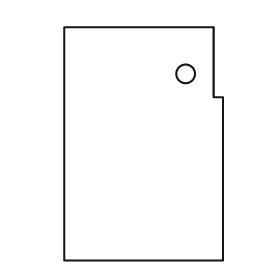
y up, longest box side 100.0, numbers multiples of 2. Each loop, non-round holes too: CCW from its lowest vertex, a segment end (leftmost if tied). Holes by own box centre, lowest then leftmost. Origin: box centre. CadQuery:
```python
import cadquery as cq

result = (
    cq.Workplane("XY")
    .moveTo(-34.0, -50.0)
    .lineTo(34.0, -50.0)
    .lineTo(34.0, 20.0)
    .lineTo(30.0, 20.0)
    .lineTo(30.0, 50.0)
    .lineTo(-34.0, 50.0)
    .close()
    .moveTo(18.0, 30.0)
    .circle(4.0)
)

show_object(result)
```